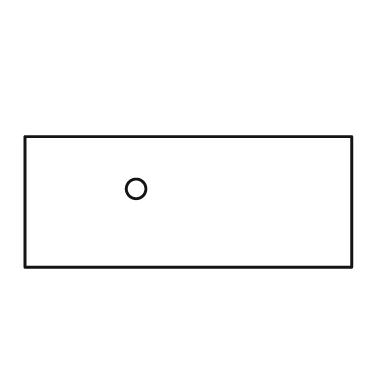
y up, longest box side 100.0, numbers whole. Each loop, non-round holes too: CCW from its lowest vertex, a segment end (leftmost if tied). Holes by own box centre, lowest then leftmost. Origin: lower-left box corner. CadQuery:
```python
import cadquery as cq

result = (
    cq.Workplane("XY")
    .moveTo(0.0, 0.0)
    .lineTo(100.0, 0.0)
    .lineTo(100.0, 40.0)
    .lineTo(0.0, 40.0)
    .close()
    .moveTo(34.0, 24.0)
    .circle(3.0)
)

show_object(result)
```